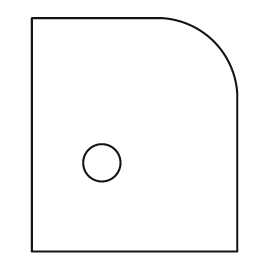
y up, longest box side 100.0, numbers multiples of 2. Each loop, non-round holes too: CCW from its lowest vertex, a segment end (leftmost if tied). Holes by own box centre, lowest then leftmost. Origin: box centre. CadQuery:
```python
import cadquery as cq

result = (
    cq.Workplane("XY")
    .moveTo(-44.0, -50.0)
    .lineTo(44.0, -50.0)
    .lineTo(44.0, 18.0)
    .threePointArc((34.0, 40.0), (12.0, 50.0))
    .lineTo(-44.0, 50.0)
    .close()
    .moveTo(-14.0, -12.0)
    .circle(8.0)
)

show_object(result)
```